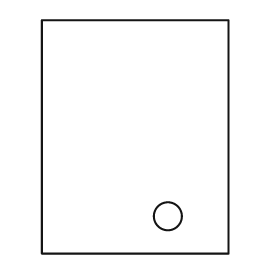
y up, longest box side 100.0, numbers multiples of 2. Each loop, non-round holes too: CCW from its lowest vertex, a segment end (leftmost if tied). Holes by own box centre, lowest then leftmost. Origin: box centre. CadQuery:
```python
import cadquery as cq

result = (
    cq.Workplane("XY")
    .moveTo(-40.0, -50.0)
    .lineTo(40.0, -50.0)
    .lineTo(40.0, 50.0)
    .lineTo(-40.0, 50.0)
    .close()
    .moveTo(14.0, -34.0)
    .circle(6.0)
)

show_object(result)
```